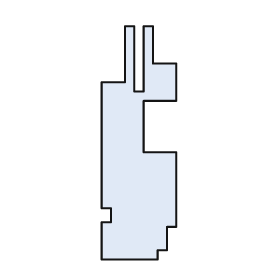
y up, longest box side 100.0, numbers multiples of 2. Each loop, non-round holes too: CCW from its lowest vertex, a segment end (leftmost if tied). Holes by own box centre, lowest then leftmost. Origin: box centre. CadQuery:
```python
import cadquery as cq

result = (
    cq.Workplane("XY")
    .moveTo(-16.0, -50.0)
    .lineTo(8.0, -50.0)
    .lineTo(8.0, -46.0)
    .lineTo(12.0, -46.0)
    .lineTo(12.0, -36.0)
    .lineTo(16.0, -36.0)
    .lineTo(16.0, -4.0)
    .lineTo(2.0, -4.0)
    .lineTo(2.0, 18.0)
    .lineTo(16.0, 18.0)
    .lineTo(16.0, 34.0)
    .lineTo(6.0, 34.0)
    .lineTo(6.0, 50.0)
    .lineTo(2.0, 50.0)
    .lineTo(2.0, 22.0)
    .lineTo(-2.0, 22.0)
    .lineTo(-2.0, 50.0)
    .lineTo(-6.0, 50.0)
    .lineTo(-6.0, 26.0)
    .lineTo(-16.0, 26.0)
    .lineTo(-16.0, -28.0)
    .lineTo(-12.0, -28.0)
    .lineTo(-12.0, -34.0)
    .lineTo(-16.0, -34.0)
    .close()
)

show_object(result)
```